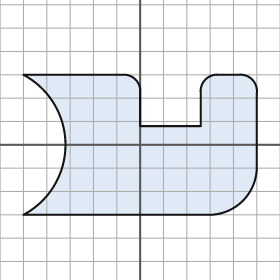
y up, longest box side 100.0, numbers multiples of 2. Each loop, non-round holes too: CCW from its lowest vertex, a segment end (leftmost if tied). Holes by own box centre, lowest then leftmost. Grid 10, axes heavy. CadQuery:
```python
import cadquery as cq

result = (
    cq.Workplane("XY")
    .moveTo(-50.0, -30.0)
    .lineTo(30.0, -30.0)
    .threePointArc((44.0, -24.0), (50.0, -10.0))
    .lineTo(50.0, 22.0)
    .threePointArc((48.0, 28.0), (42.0, 30.0))
    .lineTo(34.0, 30.0)
    .threePointArc((28.0, 28.0), (26.0, 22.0))
    .lineTo(26.0, 8.0)
    .lineTo(0.0, 8.0)
    .lineTo(0.0, 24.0)
    .threePointArc((-2.0, 28.0), (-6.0, 30.0))
    .lineTo(-50.0, 30.0)
    .threePointArc((-32.0, 0.0), (-50.0, -30.0))
    .close()
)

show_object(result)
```